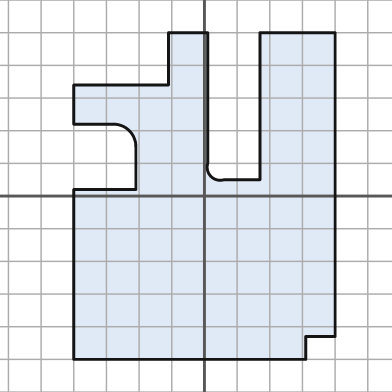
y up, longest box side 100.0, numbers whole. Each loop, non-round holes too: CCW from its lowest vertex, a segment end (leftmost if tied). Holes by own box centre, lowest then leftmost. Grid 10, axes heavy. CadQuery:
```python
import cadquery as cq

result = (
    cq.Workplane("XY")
    .moveTo(-40.0, -50.0)
    .lineTo(31.0, -50.0)
    .lineTo(31.0, -43.0)
    .lineTo(40.0, -43.0)
    .lineTo(40.0, 50.0)
    .lineTo(17.0, 50.0)
    .lineTo(17.0, 5.0)
    .lineTo(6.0, 5.0)
    .threePointArc((2.0, 6.0), (1.0, 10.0))
    .lineTo(1.0, 50.0)
    .lineTo(-11.0, 50.0)
    .lineTo(-11.0, 34.0)
    .lineTo(-40.0, 34.0)
    .lineTo(-40.0, 22.0)
    .lineTo(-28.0, 22.0)
    .threePointArc((-23.0, 20.0), (-21.0, 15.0))
    .lineTo(-21.0, 2.0)
    .lineTo(-40.0, 2.0)
    .close()
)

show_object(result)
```